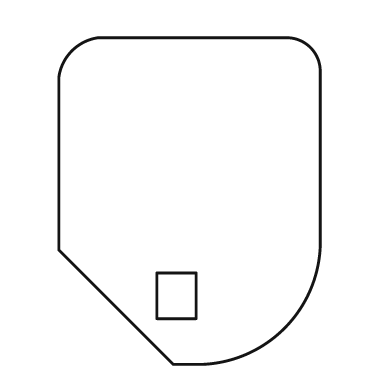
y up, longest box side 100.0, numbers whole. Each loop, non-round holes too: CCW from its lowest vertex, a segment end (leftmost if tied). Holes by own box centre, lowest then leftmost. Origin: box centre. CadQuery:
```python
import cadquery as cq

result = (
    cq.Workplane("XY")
    .moveTo(-5.0, -50.0)
    .lineTo(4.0, -50.0)
    .threePointArc((29.0, -39.0), (40.0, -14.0))
    .lineTo(40.0, 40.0)
    .threePointArc((37.0, 47.0), (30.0, 50.0))
    .lineTo(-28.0, 50.0)
    .threePointArc((-36.0, 46.0), (-40.0, 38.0))
    .lineTo(-40.0, -15.0)
    .close()
    .moveTo(-10.0, -36.0)
    .lineTo(2.0, -36.0)
    .lineTo(2.0, -22.0)
    .lineTo(-10.0, -22.0)
    .close()
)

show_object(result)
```